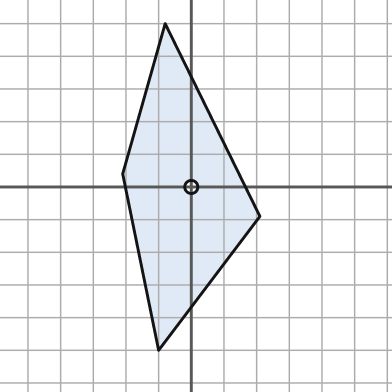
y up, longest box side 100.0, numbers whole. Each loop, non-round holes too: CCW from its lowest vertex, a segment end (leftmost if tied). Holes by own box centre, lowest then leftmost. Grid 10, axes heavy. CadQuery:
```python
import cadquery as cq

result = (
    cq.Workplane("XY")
    .moveTo(-10.0, -50.0)
    .lineTo(21.0, -9.0)
    .lineTo(-8.0, 50.0)
    .lineTo(-21.0, 4.0)
    .close()
    .moveTo(0.0, 0.0)
    .circle(2.0)
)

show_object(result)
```